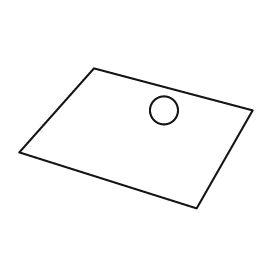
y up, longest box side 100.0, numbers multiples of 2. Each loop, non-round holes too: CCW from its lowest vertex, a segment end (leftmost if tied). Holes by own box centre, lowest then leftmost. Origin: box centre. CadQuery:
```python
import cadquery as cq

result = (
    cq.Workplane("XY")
    .moveTo(26.0, -30.0)
    .lineTo(50.0, 12.0)
    .lineTo(-18.0, 30.0)
    .lineTo(-50.0, -6.0)
    .close()
    .moveTo(12.0, 12.0)
    .circle(6.0)
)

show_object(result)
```